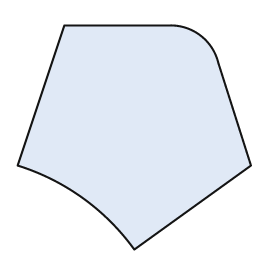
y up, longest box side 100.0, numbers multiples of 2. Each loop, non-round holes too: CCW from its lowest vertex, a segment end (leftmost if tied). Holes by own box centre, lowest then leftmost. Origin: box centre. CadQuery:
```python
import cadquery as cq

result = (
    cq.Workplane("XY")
    .moveTo(0.0, -48.0)
    .lineTo(50.0, -12.0)
    .lineTo(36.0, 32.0)
    .threePointArc((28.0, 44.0), (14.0, 48.0))
    .lineTo(-30.0, 48.0)
    .lineTo(-50.0, -12.0)
    .threePointArc((-22.0, -26.0), (0.0, -48.0))
    .close()
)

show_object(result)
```